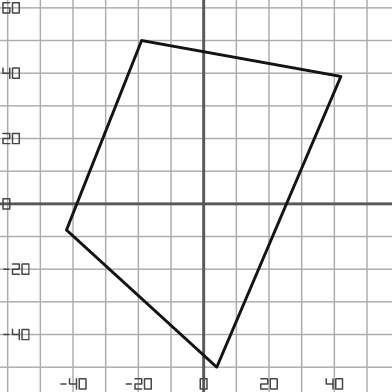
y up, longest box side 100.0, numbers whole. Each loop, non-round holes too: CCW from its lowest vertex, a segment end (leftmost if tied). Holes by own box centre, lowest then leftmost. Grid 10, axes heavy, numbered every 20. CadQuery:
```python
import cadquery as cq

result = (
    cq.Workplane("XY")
    .moveTo(4.0, -50.0)
    .lineTo(42.0, 39.0)
    .lineTo(-19.0, 50.0)
    .lineTo(-42.0, -8.0)
    .close()
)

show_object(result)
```